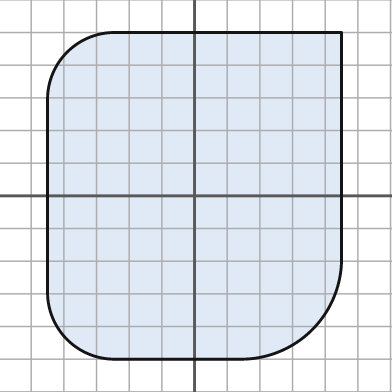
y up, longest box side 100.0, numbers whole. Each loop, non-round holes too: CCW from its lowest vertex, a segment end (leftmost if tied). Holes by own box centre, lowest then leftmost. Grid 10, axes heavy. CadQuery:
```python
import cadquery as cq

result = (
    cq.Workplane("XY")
    .moveTo(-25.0, -50.0)
    .lineTo(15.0, -50.0)
    .threePointArc((36.0, -41.0), (45.0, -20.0))
    .lineTo(45.0, 50.0)
    .lineTo(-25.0, 50.0)
    .threePointArc((-39.0, 44.0), (-45.0, 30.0))
    .lineTo(-45.0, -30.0)
    .threePointArc((-39.0, -44.0), (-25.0, -50.0))
    .close()
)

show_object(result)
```